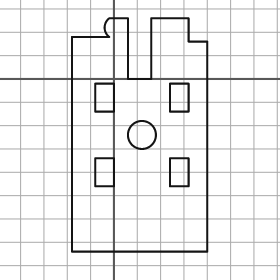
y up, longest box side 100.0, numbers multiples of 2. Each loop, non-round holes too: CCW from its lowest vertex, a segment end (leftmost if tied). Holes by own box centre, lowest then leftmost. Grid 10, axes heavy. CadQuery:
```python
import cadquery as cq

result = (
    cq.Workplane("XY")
    .moveTo(-18.0, -74.0)
    .lineTo(40.0, -74.0)
    .lineTo(40.0, 16.0)
    .lineTo(32.0, 16.0)
    .lineTo(32.0, 26.0)
    .lineTo(16.0, 26.0)
    .lineTo(16.0, 0.0)
    .lineTo(6.0, 0.0)
    .lineTo(6.0, 26.0)
    .lineTo(-2.0, 26.0)
    .threePointArc((-4.0, 22.0), (-2.0, 18.0))
    .lineTo(-18.0, 18.0)
    .close()
    .moveTo(-8.0, -46.0)
    .lineTo(0.0, -46.0)
    .lineTo(0.0, -34.0)
    .lineTo(-8.0, -34.0)
    .close()
    .moveTo(24.0, -46.0)
    .lineTo(32.0, -46.0)
    .lineTo(32.0, -34.0)
    .lineTo(24.0, -34.0)
    .close()
    .moveTo(12.0, -24.0)
    .circle(6.0)
    .moveTo(-8.0, -14.0)
    .lineTo(0.0, -14.0)
    .lineTo(0.0, -2.0)
    .lineTo(-8.0, -2.0)
    .close()
    .moveTo(24.0, -14.0)
    .lineTo(32.0, -14.0)
    .lineTo(32.0, -2.0)
    .lineTo(24.0, -2.0)
    .close()
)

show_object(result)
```